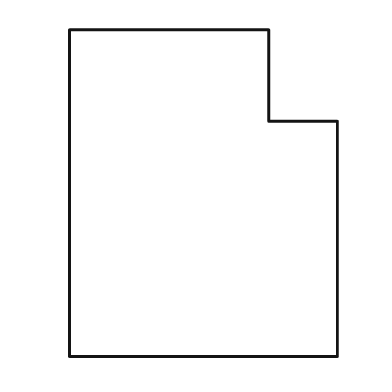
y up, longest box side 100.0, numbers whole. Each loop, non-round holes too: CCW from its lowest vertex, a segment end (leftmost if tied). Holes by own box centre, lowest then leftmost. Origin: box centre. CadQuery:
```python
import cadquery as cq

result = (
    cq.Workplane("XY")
    .moveTo(-41.0, -50.0)
    .lineTo(41.0, -50.0)
    .lineTo(41.0, 22.0)
    .lineTo(20.0, 22.0)
    .lineTo(20.0, 50.0)
    .lineTo(-41.0, 50.0)
    .close()
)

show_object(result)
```